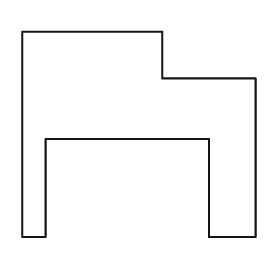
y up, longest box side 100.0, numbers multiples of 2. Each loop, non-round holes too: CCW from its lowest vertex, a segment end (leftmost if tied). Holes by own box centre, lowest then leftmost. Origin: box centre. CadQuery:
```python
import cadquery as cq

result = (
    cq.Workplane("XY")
    .moveTo(-50.0, -44.0)
    .lineTo(-40.0, -44.0)
    .lineTo(-40.0, -2.0)
    .lineTo(30.0, -2.0)
    .lineTo(30.0, -44.0)
    .lineTo(50.0, -44.0)
    .lineTo(50.0, 24.0)
    .lineTo(10.0, 24.0)
    .lineTo(10.0, 44.0)
    .lineTo(-50.0, 44.0)
    .close()
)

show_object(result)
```